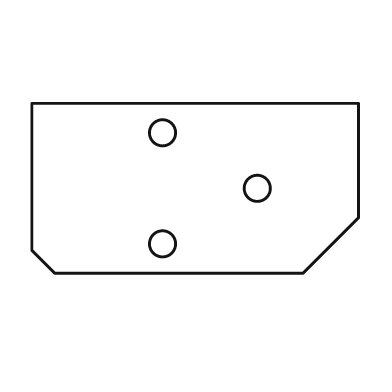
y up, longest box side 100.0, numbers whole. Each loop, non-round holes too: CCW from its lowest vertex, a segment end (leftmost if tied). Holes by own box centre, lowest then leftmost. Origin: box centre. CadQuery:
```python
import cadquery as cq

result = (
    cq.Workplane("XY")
    .moveTo(-43.0, -26.0)
    .lineTo(33.0, -26.0)
    .lineTo(50.0, -9.0)
    .lineTo(50.0, 26.0)
    .lineTo(-50.0, 26.0)
    .lineTo(-50.0, -19.0)
    .close()
    .moveTo(-10.0, -17.0)
    .circle(4.0)
    .moveTo(19.0, 0.0)
    .circle(4.0)
    .moveTo(-10.0, 17.0)
    .circle(4.0)
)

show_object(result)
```